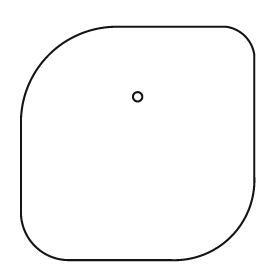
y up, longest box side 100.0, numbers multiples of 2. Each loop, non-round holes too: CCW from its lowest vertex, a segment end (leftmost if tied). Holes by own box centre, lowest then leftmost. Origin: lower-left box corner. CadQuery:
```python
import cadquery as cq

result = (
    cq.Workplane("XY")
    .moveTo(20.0, 0.0)
    .lineTo(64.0, 0.0)
    .threePointArc((90.0, 10.0), (100.0, 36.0))
    .lineTo(100.0, 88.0)
    .threePointArc((96.0, 96.0), (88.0, 100.0))
    .lineTo(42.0, 100.0)
    .threePointArc((12.0, 88.0), (0.0, 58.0))
    .lineTo(0.0, 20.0)
    .threePointArc((6.0, 6.0), (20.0, 0.0))
    .close()
    .moveTo(50.0, 70.0)
    .circle(2.0)
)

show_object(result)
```